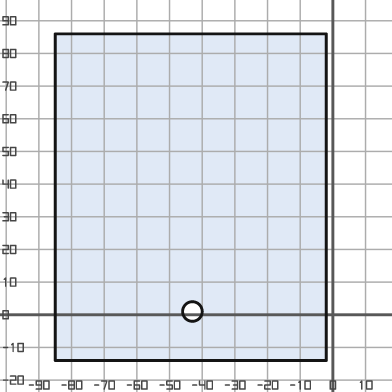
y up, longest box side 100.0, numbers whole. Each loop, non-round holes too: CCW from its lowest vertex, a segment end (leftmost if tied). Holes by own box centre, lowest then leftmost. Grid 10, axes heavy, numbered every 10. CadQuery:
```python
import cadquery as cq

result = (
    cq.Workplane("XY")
    .moveTo(-85.0, -14.0)
    .lineTo(-2.0, -14.0)
    .lineTo(-2.0, 86.0)
    .lineTo(-85.0, 86.0)
    .close()
    .moveTo(-43.0, 1.0)
    .circle(3.0)
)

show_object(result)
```